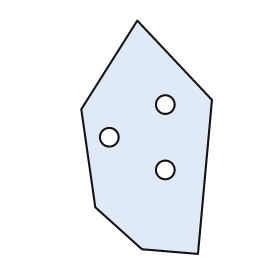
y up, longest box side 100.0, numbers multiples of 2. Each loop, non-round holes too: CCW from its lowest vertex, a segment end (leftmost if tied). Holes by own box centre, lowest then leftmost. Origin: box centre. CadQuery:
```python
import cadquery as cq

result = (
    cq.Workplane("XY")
    .moveTo(22.0, -50.0)
    .lineTo(28.0, 16.0)
    .lineTo(-4.0, 50.0)
    .lineTo(-28.0, 12.0)
    .lineTo(-22.0, -30.0)
    .lineTo(-2.0, -48.0)
    .close()
    .moveTo(8.0, -14.0)
    .circle(4.0)
    .moveTo(-16.0, 0.0)
    .circle(4.0)
    .moveTo(8.0, 14.0)
    .circle(4.0)
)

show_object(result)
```